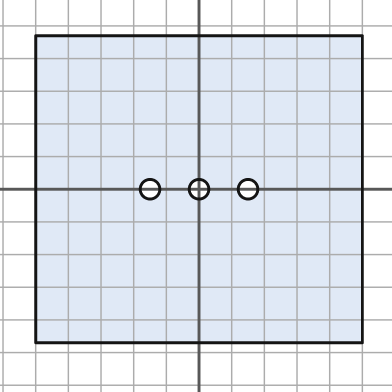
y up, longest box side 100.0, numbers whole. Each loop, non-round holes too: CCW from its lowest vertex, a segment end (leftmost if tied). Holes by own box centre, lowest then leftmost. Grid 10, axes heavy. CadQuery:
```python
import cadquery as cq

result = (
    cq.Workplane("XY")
    .moveTo(-50.0, -47.0)
    .lineTo(50.0, -47.0)
    .lineTo(50.0, 47.0)
    .lineTo(-50.0, 47.0)
    .close()
    .moveTo(-15.0, 0.0)
    .circle(3.0)
    .moveTo(0.0, 0.0)
    .circle(3.0)
    .moveTo(15.0, 0.0)
    .circle(3.0)
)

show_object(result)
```